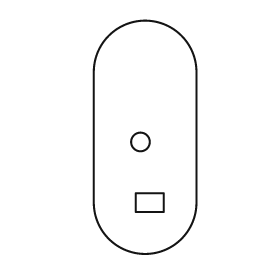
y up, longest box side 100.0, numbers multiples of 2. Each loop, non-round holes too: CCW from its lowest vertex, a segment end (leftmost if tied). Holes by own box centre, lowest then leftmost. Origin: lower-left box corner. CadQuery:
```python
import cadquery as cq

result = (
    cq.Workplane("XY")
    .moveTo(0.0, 22.0)
    .threePointArc((22.0, 0.0), (44.0, 22.0))
    .lineTo(44.0, 78.0)
    .threePointArc((22.0, 100.0), (0.0, 78.0))
    .close()
    .moveTo(18.0, 18.0)
    .lineTo(30.0, 18.0)
    .lineTo(30.0, 26.0)
    .lineTo(18.0, 26.0)
    .close()
    .moveTo(20.0, 48.0)
    .circle(4.0)
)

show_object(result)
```